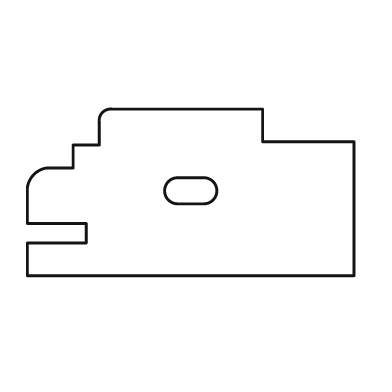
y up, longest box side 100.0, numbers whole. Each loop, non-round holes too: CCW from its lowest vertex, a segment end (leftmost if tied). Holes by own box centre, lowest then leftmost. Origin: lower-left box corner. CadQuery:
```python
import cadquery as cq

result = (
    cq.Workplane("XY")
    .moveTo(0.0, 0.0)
    .lineTo(100.0, 0.0)
    .lineTo(100.0, 41.0)
    .lineTo(72.0, 41.0)
    .lineTo(72.0, 51.0)
    .lineTo(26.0, 51.0)
    .threePointArc((23.0, 50.0), (22.0, 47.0))
    .lineTo(22.0, 40.0)
    .lineTo(14.0, 40.0)
    .lineTo(14.0, 33.0)
    .lineTo(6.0, 33.0)
    .threePointArc((2.0, 31.0), (0.0, 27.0))
    .lineTo(0.0, 16.0)
    .lineTo(18.0, 16.0)
    .lineTo(18.0, 10.0)
    .lineTo(0.0, 10.0)
    .close()
    .moveTo(46.0, 22.0)
    .lineTo(54.0, 22.0)
    .threePointArc((58.0, 26.0), (54.0, 30.0))
    .lineTo(46.0, 30.0)
    .threePointArc((42.0, 26.0), (46.0, 22.0))
    .close()
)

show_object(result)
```